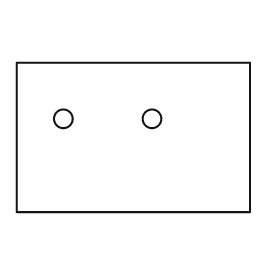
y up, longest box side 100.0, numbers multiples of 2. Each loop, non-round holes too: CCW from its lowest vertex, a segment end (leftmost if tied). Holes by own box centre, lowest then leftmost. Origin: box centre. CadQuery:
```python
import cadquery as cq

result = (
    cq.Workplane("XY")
    .moveTo(-50.0, -32.0)
    .lineTo(50.0, -32.0)
    .lineTo(50.0, 32.0)
    .lineTo(-50.0, 32.0)
    .close()
    .moveTo(-30.0, 8.0)
    .circle(4.0)
    .moveTo(8.0, 8.0)
    .circle(4.0)
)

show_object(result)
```